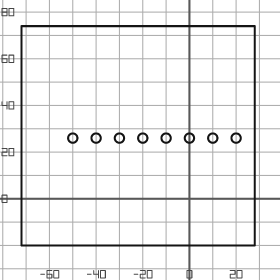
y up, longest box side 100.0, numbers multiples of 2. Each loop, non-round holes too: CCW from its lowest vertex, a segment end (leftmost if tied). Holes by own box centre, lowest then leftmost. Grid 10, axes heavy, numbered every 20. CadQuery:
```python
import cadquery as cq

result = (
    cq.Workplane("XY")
    .moveTo(-72.0, -20.0)
    .lineTo(28.0, -20.0)
    .lineTo(28.0, 74.0)
    .lineTo(-72.0, 74.0)
    .close()
    .moveTo(-50.0, 26.0)
    .circle(2.0)
    .moveTo(-40.0, 26.0)
    .circle(2.0)
    .moveTo(-30.0, 26.0)
    .circle(2.0)
    .moveTo(-20.0, 26.0)
    .circle(2.0)
    .moveTo(-10.0, 26.0)
    .circle(2.0)
    .moveTo(0.0, 26.0)
    .circle(2.0)
    .moveTo(10.0, 26.0)
    .circle(2.0)
    .moveTo(20.0, 26.0)
    .circle(2.0)
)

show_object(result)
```